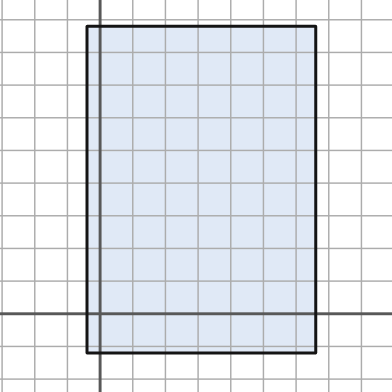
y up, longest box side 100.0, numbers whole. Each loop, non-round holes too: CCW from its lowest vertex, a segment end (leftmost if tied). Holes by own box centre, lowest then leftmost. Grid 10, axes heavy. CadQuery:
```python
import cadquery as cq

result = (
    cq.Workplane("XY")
    .moveTo(-4.0, -12.0)
    .lineTo(66.0, -12.0)
    .lineTo(66.0, 88.0)
    .lineTo(-4.0, 88.0)
    .close()
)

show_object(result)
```